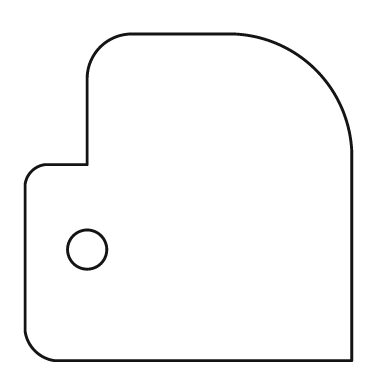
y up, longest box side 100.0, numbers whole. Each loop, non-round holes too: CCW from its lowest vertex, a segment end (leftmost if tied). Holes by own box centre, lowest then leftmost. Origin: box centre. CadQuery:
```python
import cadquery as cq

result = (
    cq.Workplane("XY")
    .moveTo(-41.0, -50.0)
    .lineTo(50.0, -50.0)
    .lineTo(50.0, 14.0)
    .threePointArc((39.0, 39.0), (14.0, 50.0))
    .lineTo(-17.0, 50.0)
    .threePointArc((-27.0, 46.0), (-31.0, 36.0))
    .lineTo(-31.0, 10.0)
    .lineTo(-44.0, 10.0)
    .threePointArc((-48.0, 8.0), (-50.0, 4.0))
    .lineTo(-50.0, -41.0)
    .threePointArc((-47.0, -47.0), (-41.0, -50.0))
    .close()
    .moveTo(-31.0, -16.0)
    .circle(6.0)
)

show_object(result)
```